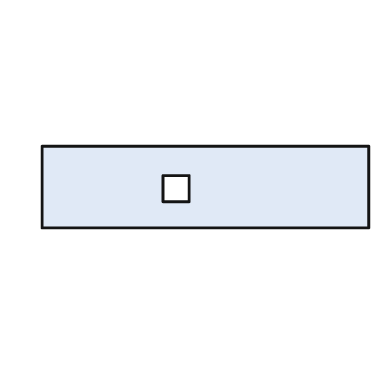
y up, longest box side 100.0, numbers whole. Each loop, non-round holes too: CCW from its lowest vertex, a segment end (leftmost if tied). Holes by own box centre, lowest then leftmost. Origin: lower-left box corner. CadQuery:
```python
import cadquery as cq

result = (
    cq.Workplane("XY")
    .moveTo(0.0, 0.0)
    .lineTo(100.0, 0.0)
    .lineTo(100.0, 25.0)
    .lineTo(0.0, 25.0)
    .close()
    .moveTo(37.0, 8.0)
    .lineTo(45.0, 8.0)
    .lineTo(45.0, 16.0)
    .lineTo(37.0, 16.0)
    .close()
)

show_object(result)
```